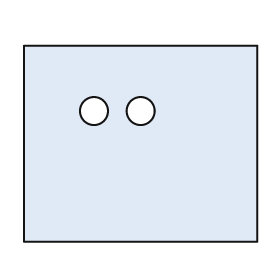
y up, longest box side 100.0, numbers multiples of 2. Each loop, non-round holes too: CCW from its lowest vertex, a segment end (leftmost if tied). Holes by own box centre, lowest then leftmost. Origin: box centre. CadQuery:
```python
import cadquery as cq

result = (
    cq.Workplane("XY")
    .moveTo(-50.0, -42.0)
    .lineTo(50.0, -42.0)
    .lineTo(50.0, 42.0)
    .lineTo(-50.0, 42.0)
    .close()
    .moveTo(-20.0, 14.0)
    .circle(6.0)
    .moveTo(0.0, 14.0)
    .circle(6.0)
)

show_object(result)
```